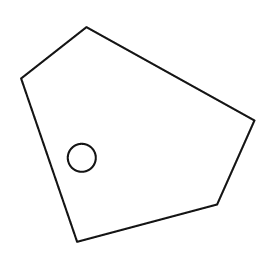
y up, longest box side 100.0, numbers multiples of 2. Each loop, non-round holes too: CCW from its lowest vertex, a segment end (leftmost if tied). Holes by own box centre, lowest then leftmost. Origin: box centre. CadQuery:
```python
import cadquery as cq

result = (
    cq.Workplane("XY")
    .moveTo(-26.0, -46.0)
    .lineTo(34.0, -30.0)
    .lineTo(50.0, 6.0)
    .lineTo(-22.0, 46.0)
    .lineTo(-50.0, 24.0)
    .close()
    .moveTo(-24.0, -10.0)
    .circle(6.0)
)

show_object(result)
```